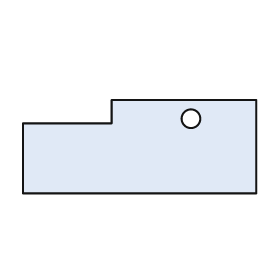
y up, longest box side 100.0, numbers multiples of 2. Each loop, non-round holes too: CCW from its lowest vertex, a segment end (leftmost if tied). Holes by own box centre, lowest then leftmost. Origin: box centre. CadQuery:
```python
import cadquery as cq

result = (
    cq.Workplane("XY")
    .moveTo(-50.0, -20.0)
    .lineTo(50.0, -20.0)
    .lineTo(50.0, 20.0)
    .lineTo(-12.0, 20.0)
    .lineTo(-12.0, 10.0)
    .lineTo(-50.0, 10.0)
    .close()
    .moveTo(22.0, 12.0)
    .circle(4.0)
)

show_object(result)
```